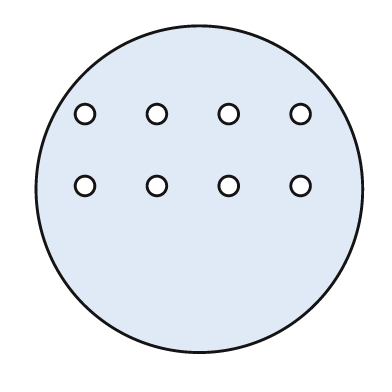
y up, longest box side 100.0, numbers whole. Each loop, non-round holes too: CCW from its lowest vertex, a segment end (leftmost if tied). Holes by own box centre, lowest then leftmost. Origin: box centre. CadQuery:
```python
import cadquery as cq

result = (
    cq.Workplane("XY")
    .moveTo(0.0, 0.0)
    .circle(50.0)
    .moveTo(-35.0, 1.0)
    .circle(3.0)
    .moveTo(-13.0, 1.0)
    .circle(3.0)
    .moveTo(9.0, 1.0)
    .circle(3.0)
    .moveTo(31.0, 1.0)
    .circle(3.0)
    .moveTo(-35.0, 23.0)
    .circle(3.0)
    .moveTo(-13.0, 23.0)
    .circle(3.0)
    .moveTo(9.0, 23.0)
    .circle(3.0)
    .moveTo(31.0, 23.0)
    .circle(3.0)
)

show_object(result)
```